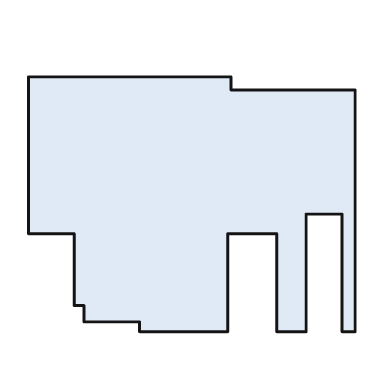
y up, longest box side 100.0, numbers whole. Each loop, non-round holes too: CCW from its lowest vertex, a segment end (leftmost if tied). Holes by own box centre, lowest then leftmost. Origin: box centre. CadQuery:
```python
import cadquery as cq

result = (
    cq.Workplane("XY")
    .moveTo(-16.0, -39.0)
    .lineTo(11.0, -39.0)
    .lineTo(11.0, -9.0)
    .lineTo(26.0, -9.0)
    .lineTo(26.0, -39.0)
    .lineTo(35.0, -39.0)
    .lineTo(35.0, -3.0)
    .lineTo(46.0, -3.0)
    .lineTo(46.0, -39.0)
    .lineTo(50.0, -39.0)
    .lineTo(50.0, 35.0)
    .lineTo(12.0, 35.0)
    .lineTo(12.0, 39.0)
    .lineTo(-50.0, 39.0)
    .lineTo(-50.0, -9.0)
    .lineTo(-36.0, -9.0)
    .lineTo(-36.0, -31.0)
    .lineTo(-33.0, -31.0)
    .lineTo(-33.0, -36.0)
    .lineTo(-16.0, -36.0)
    .close()
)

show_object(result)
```